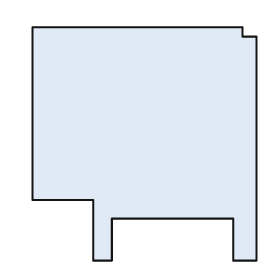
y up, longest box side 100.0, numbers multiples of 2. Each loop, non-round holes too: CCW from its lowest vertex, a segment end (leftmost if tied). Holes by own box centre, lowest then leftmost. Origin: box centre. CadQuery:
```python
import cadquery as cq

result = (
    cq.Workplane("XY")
    .moveTo(-22.0, -50.0)
    .lineTo(-14.0, -50.0)
    .lineTo(-14.0, -32.0)
    .lineTo(38.0, -32.0)
    .lineTo(38.0, -50.0)
    .lineTo(48.0, -50.0)
    .lineTo(48.0, 46.0)
    .lineTo(42.0, 46.0)
    .lineTo(42.0, 50.0)
    .lineTo(-48.0, 50.0)
    .lineTo(-48.0, -24.0)
    .lineTo(-22.0, -24.0)
    .close()
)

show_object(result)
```